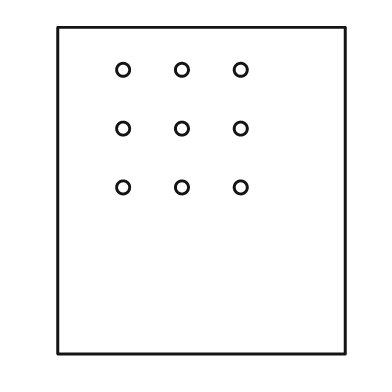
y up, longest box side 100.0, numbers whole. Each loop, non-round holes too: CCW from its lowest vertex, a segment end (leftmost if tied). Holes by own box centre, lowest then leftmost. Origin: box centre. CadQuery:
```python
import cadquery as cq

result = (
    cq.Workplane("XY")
    .moveTo(-44.0, -50.0)
    .lineTo(44.0, -50.0)
    .lineTo(44.0, 50.0)
    .lineTo(-44.0, 50.0)
    .close()
    .moveTo(-24.0, 1.0)
    .circle(2.0)
    .moveTo(-6.0, 1.0)
    .circle(2.0)
    .moveTo(12.0, 1.0)
    .circle(2.0)
    .moveTo(-24.0, 19.0)
    .circle(2.0)
    .moveTo(-6.0, 19.0)
    .circle(2.0)
    .moveTo(12.0, 19.0)
    .circle(2.0)
    .moveTo(-24.0, 37.0)
    .circle(2.0)
    .moveTo(-6.0, 37.0)
    .circle(2.0)
    .moveTo(12.0, 37.0)
    .circle(2.0)
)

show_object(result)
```